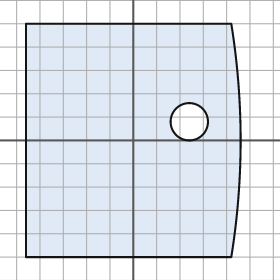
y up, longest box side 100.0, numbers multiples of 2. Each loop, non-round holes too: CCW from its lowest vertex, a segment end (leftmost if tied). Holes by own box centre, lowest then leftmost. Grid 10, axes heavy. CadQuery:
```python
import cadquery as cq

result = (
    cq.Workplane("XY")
    .moveTo(-46.0, -50.0)
    .lineTo(42.0, -50.0)
    .threePointArc((46.0, 0.0), (42.0, 50.0))
    .lineTo(-46.0, 50.0)
    .close()
    .moveTo(24.0, 8.0)
    .circle(8.0)
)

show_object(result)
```